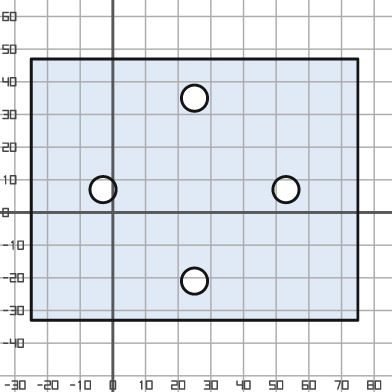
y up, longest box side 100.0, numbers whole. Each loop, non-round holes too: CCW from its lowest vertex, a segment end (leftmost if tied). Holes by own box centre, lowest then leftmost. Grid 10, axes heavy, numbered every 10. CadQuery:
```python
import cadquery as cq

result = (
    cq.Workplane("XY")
    .moveTo(-25.0, -33.0)
    .lineTo(75.0, -33.0)
    .lineTo(75.0, 47.0)
    .lineTo(-25.0, 47.0)
    .close()
    .moveTo(25.0, -21.0)
    .circle(4.0)
    .moveTo(-3.0, 7.0)
    .circle(4.0)
    .moveTo(53.0, 7.0)
    .circle(4.0)
    .moveTo(25.0, 35.0)
    .circle(4.0)
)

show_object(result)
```